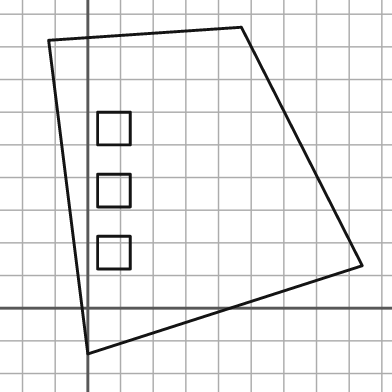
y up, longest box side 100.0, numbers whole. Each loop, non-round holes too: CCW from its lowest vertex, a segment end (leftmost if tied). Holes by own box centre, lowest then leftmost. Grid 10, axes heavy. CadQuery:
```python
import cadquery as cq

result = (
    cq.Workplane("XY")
    .moveTo(0.0, -14.0)
    .lineTo(84.0, 13.0)
    .lineTo(47.0, 86.0)
    .lineTo(-12.0, 82.0)
    .close()
    .moveTo(3.0, 12.0)
    .lineTo(13.0, 12.0)
    .lineTo(13.0, 22.0)
    .lineTo(3.0, 22.0)
    .close()
    .moveTo(3.0, 31.0)
    .lineTo(13.0, 31.0)
    .lineTo(13.0, 41.0)
    .lineTo(3.0, 41.0)
    .close()
    .moveTo(3.0, 50.0)
    .lineTo(13.0, 50.0)
    .lineTo(13.0, 60.0)
    .lineTo(3.0, 60.0)
    .close()
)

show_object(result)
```